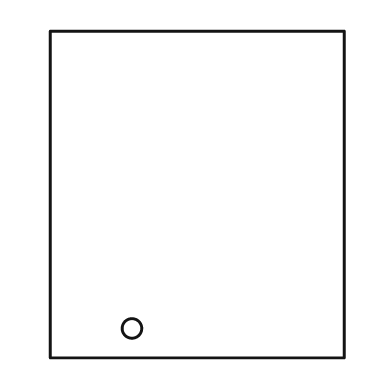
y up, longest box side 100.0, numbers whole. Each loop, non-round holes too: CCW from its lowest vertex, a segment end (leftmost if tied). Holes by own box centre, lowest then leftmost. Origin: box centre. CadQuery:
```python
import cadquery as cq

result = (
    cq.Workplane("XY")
    .moveTo(-45.0, -50.0)
    .lineTo(45.0, -50.0)
    .lineTo(45.0, 50.0)
    .lineTo(-45.0, 50.0)
    .close()
    .moveTo(-20.0, -41.0)
    .circle(3.0)
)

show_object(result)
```